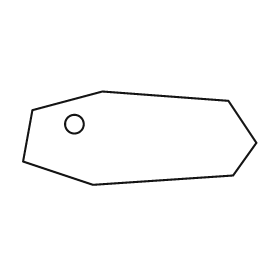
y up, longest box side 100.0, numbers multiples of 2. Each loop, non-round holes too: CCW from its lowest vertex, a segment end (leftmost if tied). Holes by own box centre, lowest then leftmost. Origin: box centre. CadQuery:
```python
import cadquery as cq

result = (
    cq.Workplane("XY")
    .moveTo(-20.0, -20.0)
    .lineTo(40.0, -16.0)
    .lineTo(50.0, -2.0)
    .lineTo(38.0, 16.0)
    .lineTo(-16.0, 20.0)
    .lineTo(-46.0, 12.0)
    .lineTo(-50.0, -10.0)
    .close()
    .moveTo(-28.0, 6.0)
    .circle(4.0)
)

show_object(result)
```